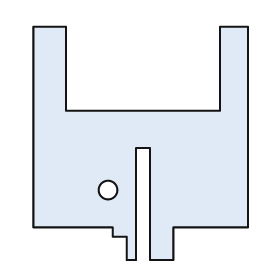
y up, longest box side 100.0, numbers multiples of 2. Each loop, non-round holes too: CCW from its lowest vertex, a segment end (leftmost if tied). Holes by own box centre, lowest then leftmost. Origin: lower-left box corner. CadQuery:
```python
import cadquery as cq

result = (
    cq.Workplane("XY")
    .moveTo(40.0, 0.0)
    .lineTo(44.0, 0.0)
    .lineTo(44.0, 48.0)
    .lineTo(50.0, 48.0)
    .lineTo(50.0, 0.0)
    .lineTo(60.0, 0.0)
    .lineTo(60.0, 14.0)
    .lineTo(92.0, 14.0)
    .lineTo(92.0, 100.0)
    .lineTo(80.0, 100.0)
    .lineTo(80.0, 64.0)
    .lineTo(14.0, 64.0)
    .lineTo(14.0, 100.0)
    .lineTo(0.0, 100.0)
    .lineTo(0.0, 14.0)
    .lineTo(34.0, 14.0)
    .lineTo(34.0, 10.0)
    .lineTo(40.0, 10.0)
    .close()
    .moveTo(32.0, 30.0)
    .circle(4.0)
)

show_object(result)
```